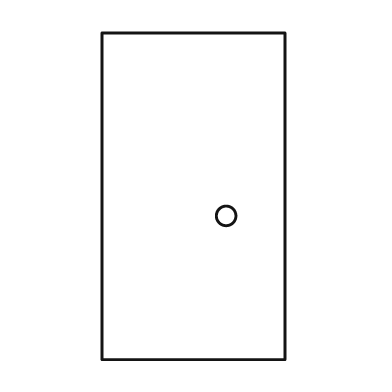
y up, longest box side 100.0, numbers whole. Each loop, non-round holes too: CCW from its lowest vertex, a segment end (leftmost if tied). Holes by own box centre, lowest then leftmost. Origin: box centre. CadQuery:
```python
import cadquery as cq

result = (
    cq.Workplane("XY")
    .moveTo(-28.0, -50.0)
    .lineTo(28.0, -50.0)
    .lineTo(28.0, 50.0)
    .lineTo(-28.0, 50.0)
    .close()
    .moveTo(10.0, -6.0)
    .circle(3.0)
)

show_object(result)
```